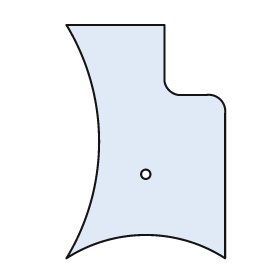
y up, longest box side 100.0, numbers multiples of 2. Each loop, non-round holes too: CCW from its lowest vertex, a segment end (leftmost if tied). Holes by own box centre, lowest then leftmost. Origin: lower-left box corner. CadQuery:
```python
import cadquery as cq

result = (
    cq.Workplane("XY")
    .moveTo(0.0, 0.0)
    .threePointArc((34.0, 10.0), (68.0, 0.0))
    .lineTo(68.0, 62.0)
    .threePointArc((66.0, 68.0), (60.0, 70.0))
    .lineTo(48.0, 70.0)
    .threePointArc((44.0, 72.0), (42.0, 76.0))
    .lineTo(42.0, 100.0)
    .lineTo(0.0, 100.0)
    .threePointArc((14.0, 50.0), (0.0, 0.0))
    .close()
    .moveTo(34.0, 36.0)
    .circle(2.0)
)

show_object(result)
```